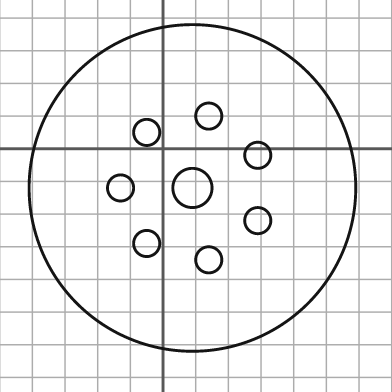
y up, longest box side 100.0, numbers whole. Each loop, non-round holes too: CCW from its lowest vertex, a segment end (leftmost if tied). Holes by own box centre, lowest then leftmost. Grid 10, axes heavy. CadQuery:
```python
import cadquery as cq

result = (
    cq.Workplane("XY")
    .moveTo(9.0, -12.0)
    .circle(50.0)
    .moveTo(14.0, -34.0)
    .circle(4.0)
    .moveTo(-5.0, -29.0)
    .circle(4.0)
    .moveTo(29.0, -22.0)
    .circle(4.0)
    .moveTo(-13.0, -12.0)
    .circle(4.0)
    .moveTo(9.0, -12.0)
    .circle(6.0)
    .moveTo(29.0, -2.0)
    .circle(4.0)
    .moveTo(-5.0, 5.0)
    .circle(4.0)
    .moveTo(14.0, 10.0)
    .circle(4.0)
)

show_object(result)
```